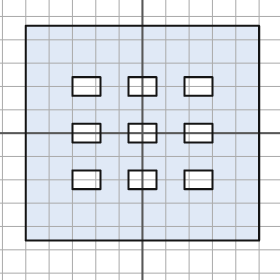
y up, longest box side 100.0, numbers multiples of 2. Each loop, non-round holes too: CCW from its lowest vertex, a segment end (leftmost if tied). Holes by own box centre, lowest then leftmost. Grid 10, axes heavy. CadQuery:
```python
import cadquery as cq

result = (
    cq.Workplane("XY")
    .moveTo(-50.0, -46.0)
    .lineTo(50.0, -46.0)
    .lineTo(50.0, 46.0)
    .lineTo(-50.0, 46.0)
    .close()
    .moveTo(-30.0, -24.0)
    .lineTo(-18.0, -24.0)
    .lineTo(-18.0, -16.0)
    .lineTo(-30.0, -16.0)
    .close()
    .moveTo(-6.0, -24.0)
    .lineTo(6.0, -24.0)
    .lineTo(6.0, -16.0)
    .lineTo(-6.0, -16.0)
    .close()
    .moveTo(18.0, -24.0)
    .lineTo(30.0, -24.0)
    .lineTo(30.0, -16.0)
    .lineTo(18.0, -16.0)
    .close()
    .moveTo(-30.0, -4.0)
    .lineTo(-18.0, -4.0)
    .lineTo(-18.0, 4.0)
    .lineTo(-30.0, 4.0)
    .close()
    .moveTo(-6.0, -4.0)
    .lineTo(6.0, -4.0)
    .lineTo(6.0, 4.0)
    .lineTo(-6.0, 4.0)
    .close()
    .moveTo(18.0, -4.0)
    .lineTo(30.0, -4.0)
    .lineTo(30.0, 4.0)
    .lineTo(18.0, 4.0)
    .close()
    .moveTo(-30.0, 16.0)
    .lineTo(-18.0, 16.0)
    .lineTo(-18.0, 24.0)
    .lineTo(-30.0, 24.0)
    .close()
    .moveTo(-6.0, 16.0)
    .lineTo(6.0, 16.0)
    .lineTo(6.0, 24.0)
    .lineTo(-6.0, 24.0)
    .close()
    .moveTo(18.0, 16.0)
    .lineTo(30.0, 16.0)
    .lineTo(30.0, 24.0)
    .lineTo(18.0, 24.0)
    .close()
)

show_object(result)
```